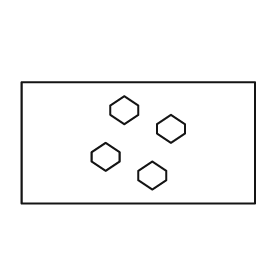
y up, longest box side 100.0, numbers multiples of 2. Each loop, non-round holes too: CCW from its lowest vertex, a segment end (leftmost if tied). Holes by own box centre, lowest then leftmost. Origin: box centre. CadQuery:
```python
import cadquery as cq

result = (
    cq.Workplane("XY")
    .moveTo(-50.0, -26.0)
    .lineTo(50.0, -26.0)
    .lineTo(50.0, 26.0)
    .lineTo(-50.0, 26.0)
    .close()
    .moveTo(6.0, -20.0)
    .lineTo(12.0, -16.0)
    .lineTo(12.0, -12.0)
    .lineTo(6.0, -8.0)
    .lineTo(0.0, -12.0)
    .lineTo(0.0, -16.0)
    .close()
    .moveTo(-14.0, -12.0)
    .lineTo(-8.0, -8.0)
    .lineTo(-8.0, -4.0)
    .lineTo(-14.0, 0.0)
    .lineTo(-20.0, -4.0)
    .lineTo(-20.0, -8.0)
    .close()
    .moveTo(14.0, 0.0)
    .lineTo(20.0, 4.0)
    .lineTo(20.0, 8.0)
    .lineTo(14.0, 12.0)
    .lineTo(8.0, 8.0)
    .lineTo(8.0, 4.0)
    .close()
    .moveTo(-6.0, 8.0)
    .lineTo(0.0, 12.0)
    .lineTo(0.0, 16.0)
    .lineTo(-6.0, 20.0)
    .lineTo(-12.0, 16.0)
    .lineTo(-12.0, 12.0)
    .close()
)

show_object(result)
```